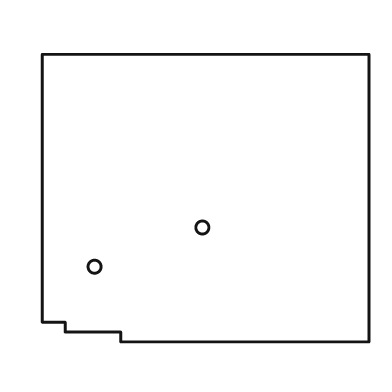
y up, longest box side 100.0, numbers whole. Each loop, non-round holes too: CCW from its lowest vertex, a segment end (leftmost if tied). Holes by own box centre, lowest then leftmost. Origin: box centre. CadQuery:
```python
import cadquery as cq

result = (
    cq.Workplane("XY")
    .moveTo(-26.0, -44.0)
    .lineTo(50.0, -44.0)
    .lineTo(50.0, 44.0)
    .lineTo(-50.0, 44.0)
    .lineTo(-50.0, -38.0)
    .lineTo(-43.0, -38.0)
    .lineTo(-43.0, -41.0)
    .lineTo(-26.0, -41.0)
    .close()
    .moveTo(-34.0, -21.0)
    .circle(2.0)
    .moveTo(-1.0, -9.0)
    .circle(2.0)
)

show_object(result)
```